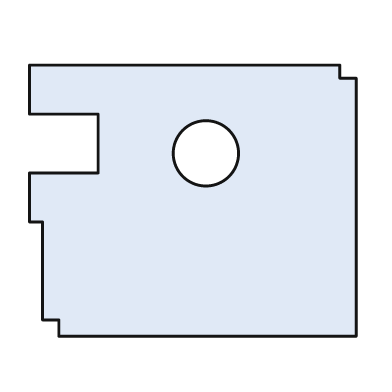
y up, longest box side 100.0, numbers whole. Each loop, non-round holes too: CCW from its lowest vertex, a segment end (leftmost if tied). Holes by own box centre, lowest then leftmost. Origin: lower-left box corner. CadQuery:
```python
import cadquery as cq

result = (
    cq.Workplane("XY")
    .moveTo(9.0, 0.0)
    .lineTo(100.0, 0.0)
    .lineTo(100.0, 79.0)
    .lineTo(95.0, 79.0)
    .lineTo(95.0, 83.0)
    .lineTo(0.0, 83.0)
    .lineTo(0.0, 68.0)
    .lineTo(21.0, 68.0)
    .lineTo(21.0, 50.0)
    .lineTo(0.0, 50.0)
    .lineTo(0.0, 35.0)
    .lineTo(4.0, 35.0)
    .lineTo(4.0, 5.0)
    .lineTo(9.0, 5.0)
    .close()
    .moveTo(54.0, 56.0)
    .circle(10.0)
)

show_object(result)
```